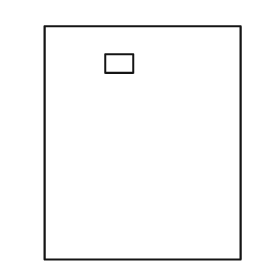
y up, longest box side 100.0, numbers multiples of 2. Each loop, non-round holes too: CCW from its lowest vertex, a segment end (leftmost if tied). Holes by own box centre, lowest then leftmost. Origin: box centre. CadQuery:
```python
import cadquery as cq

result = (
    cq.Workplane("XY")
    .moveTo(-42.0, -50.0)
    .lineTo(42.0, -50.0)
    .lineTo(42.0, 50.0)
    .lineTo(-42.0, 50.0)
    .close()
    .moveTo(-16.0, 30.0)
    .lineTo(-4.0, 30.0)
    .lineTo(-4.0, 38.0)
    .lineTo(-16.0, 38.0)
    .close()
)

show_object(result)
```